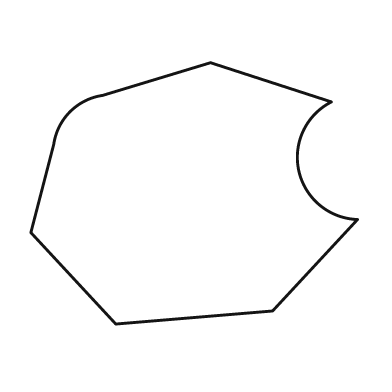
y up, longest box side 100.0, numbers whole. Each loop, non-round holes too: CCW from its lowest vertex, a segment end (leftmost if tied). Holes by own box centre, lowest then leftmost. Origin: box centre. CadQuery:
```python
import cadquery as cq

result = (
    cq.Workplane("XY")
    .moveTo(-24.0, -40.0)
    .lineTo(24.0, -36.0)
    .lineTo(50.0, -8.0)
    .threePointArc((32.0, 7.0), (42.0, 28.0))
    .lineTo(5.0, 40.0)
    .lineTo(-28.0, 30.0)
    .threePointArc((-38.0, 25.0), (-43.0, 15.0))
    .lineTo(-50.0, -12.0)
    .close()
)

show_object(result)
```